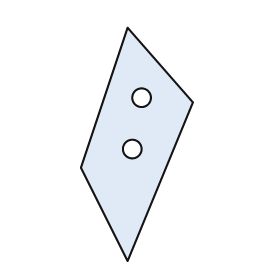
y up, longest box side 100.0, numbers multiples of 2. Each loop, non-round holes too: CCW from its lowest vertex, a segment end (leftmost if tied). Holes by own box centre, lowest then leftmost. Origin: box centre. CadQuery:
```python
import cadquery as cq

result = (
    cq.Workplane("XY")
    .moveTo(-4.0, -50.0)
    .lineTo(24.0, 18.0)
    .lineTo(-4.0, 50.0)
    .lineTo(-24.0, -10.0)
    .close()
    .moveTo(-2.0, -2.0)
    .circle(4.0)
    .moveTo(2.0, 20.0)
    .circle(4.0)
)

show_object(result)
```